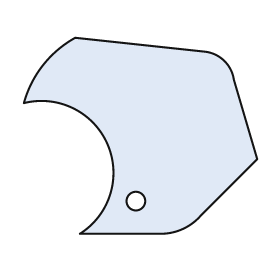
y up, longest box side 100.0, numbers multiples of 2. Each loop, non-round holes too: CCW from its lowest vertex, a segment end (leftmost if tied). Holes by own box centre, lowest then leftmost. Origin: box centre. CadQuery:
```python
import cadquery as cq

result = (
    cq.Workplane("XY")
    .moveTo(-26.0, -42.0)
    .lineTo(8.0, -42.0)
    .threePointArc((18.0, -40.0), (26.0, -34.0))
    .lineTo(50.0, -10.0)
    .lineTo(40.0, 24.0)
    .threePointArc((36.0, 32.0), (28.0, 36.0))
    .lineTo(-28.0, 42.0)
    .threePointArc((-42.0, 30.0), (-50.0, 14.0))
    .threePointArc((-14.0, -4.0), (-26.0, -42.0))
    .close()
    .moveTo(-2.0, -28.0)
    .circle(4.0)
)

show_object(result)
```